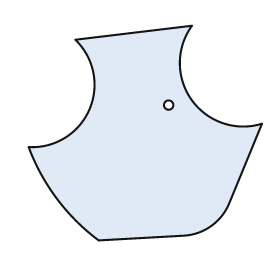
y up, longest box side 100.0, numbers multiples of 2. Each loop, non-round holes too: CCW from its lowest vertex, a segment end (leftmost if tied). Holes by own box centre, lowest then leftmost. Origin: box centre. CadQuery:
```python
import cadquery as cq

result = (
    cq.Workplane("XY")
    .moveTo(-20.0, -46.0)
    .lineTo(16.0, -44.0)
    .threePointArc((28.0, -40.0), (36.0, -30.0))
    .lineTo(50.0, 4.0)
    .threePointArc((20.0, 14.0), (20.0, 46.0))
    .lineTo(-30.0, 40.0)
    .threePointArc((-24.0, 10.0), (-50.0, -6.0))
    .threePointArc((-38.0, -28.0), (-20.0, -46.0))
    .close()
    .moveTo(10.0, 12.0)
    .circle(2.0)
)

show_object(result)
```